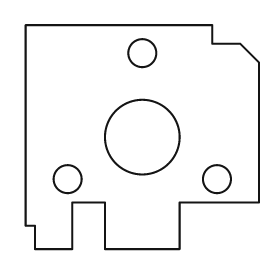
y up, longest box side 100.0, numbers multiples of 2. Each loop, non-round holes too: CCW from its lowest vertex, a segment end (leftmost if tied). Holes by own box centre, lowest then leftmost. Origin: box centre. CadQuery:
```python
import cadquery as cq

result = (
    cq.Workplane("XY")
    .moveTo(-46.0, -48.0)
    .lineTo(-30.0, -48.0)
    .lineTo(-30.0, -28.0)
    .lineTo(-16.0, -28.0)
    .lineTo(-16.0, -48.0)
    .lineTo(16.0, -48.0)
    .lineTo(16.0, -28.0)
    .lineTo(50.0, -28.0)
    .lineTo(50.0, 32.0)
    .lineTo(42.0, 40.0)
    .lineTo(30.0, 40.0)
    .lineTo(30.0, 48.0)
    .lineTo(-50.0, 48.0)
    .lineTo(-50.0, -38.0)
    .lineTo(-46.0, -38.0)
    .close()
    .moveTo(-32.0, -18.0)
    .circle(6.0)
    .moveTo(32.0, -18.0)
    .circle(6.0)
    .moveTo(0.0, 0.0)
    .circle(16.0)
    .moveTo(0.0, 36.0)
    .circle(6.0)
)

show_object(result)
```